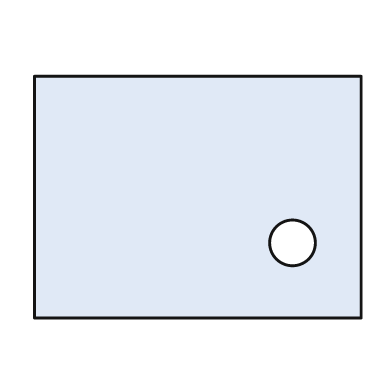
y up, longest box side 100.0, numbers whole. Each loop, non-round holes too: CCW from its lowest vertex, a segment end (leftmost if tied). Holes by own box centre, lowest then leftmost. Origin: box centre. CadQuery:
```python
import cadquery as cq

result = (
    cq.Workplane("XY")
    .moveTo(-50.0, -37.0)
    .lineTo(50.0, -37.0)
    .lineTo(50.0, 37.0)
    .lineTo(-50.0, 37.0)
    .close()
    .moveTo(29.0, -14.0)
    .circle(7.0)
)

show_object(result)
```